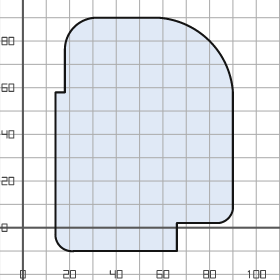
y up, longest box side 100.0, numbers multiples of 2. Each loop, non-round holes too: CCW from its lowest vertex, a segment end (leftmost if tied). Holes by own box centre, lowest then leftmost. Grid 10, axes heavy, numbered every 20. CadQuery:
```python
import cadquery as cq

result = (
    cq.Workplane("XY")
    .moveTo(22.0, -10.0)
    .lineTo(66.0, -10.0)
    .lineTo(66.0, 2.0)
    .lineTo(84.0, 2.0)
    .threePointArc((88.0, 4.0), (90.0, 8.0))
    .lineTo(90.0, 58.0)
    .threePointArc((80.0, 80.0), (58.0, 90.0))
    .lineTo(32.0, 90.0)
    .threePointArc((22.0, 86.0), (18.0, 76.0))
    .lineTo(18.0, 58.0)
    .lineTo(14.0, 58.0)
    .lineTo(14.0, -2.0)
    .threePointArc((16.0, -8.0), (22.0, -10.0))
    .close()
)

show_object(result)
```